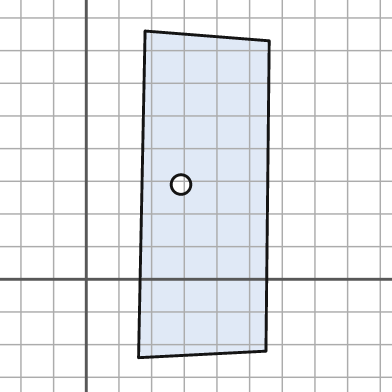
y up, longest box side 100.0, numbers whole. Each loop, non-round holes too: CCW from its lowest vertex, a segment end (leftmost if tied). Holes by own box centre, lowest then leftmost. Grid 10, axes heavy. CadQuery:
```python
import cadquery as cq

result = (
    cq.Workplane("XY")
    .moveTo(16.0, -24.0)
    .lineTo(55.0, -22.0)
    .lineTo(56.0, 73.0)
    .lineTo(18.0, 76.0)
    .close()
    .moveTo(29.0, 29.0)
    .circle(3.0)
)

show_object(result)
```